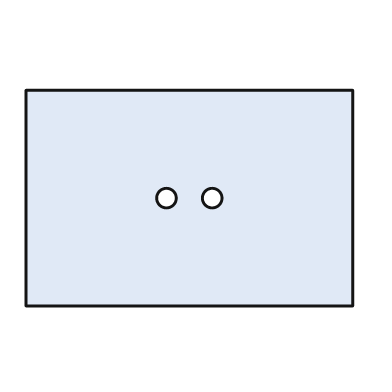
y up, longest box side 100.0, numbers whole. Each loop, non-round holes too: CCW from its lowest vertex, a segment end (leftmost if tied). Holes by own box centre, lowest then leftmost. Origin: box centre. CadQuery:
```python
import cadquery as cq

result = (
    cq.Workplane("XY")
    .moveTo(-50.0, -33.0)
    .lineTo(50.0, -33.0)
    .lineTo(50.0, 33.0)
    .lineTo(-50.0, 33.0)
    .close()
    .moveTo(-7.0, 0.0)
    .circle(3.0)
    .moveTo(7.0, 0.0)
    .circle(3.0)
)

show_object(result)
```